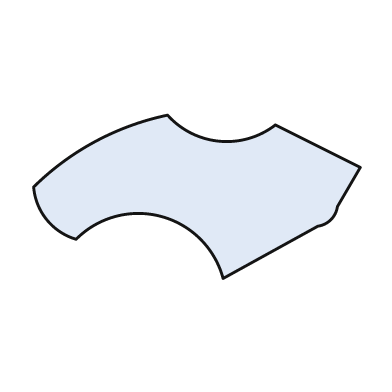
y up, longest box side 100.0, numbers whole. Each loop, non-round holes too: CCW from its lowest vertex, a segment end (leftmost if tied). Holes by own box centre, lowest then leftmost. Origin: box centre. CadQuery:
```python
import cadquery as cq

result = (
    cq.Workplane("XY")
    .moveTo(8.0, -25.0)
    .lineTo(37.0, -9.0)
    .threePointArc((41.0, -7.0), (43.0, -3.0))
    .lineTo(50.0, 9.0)
    .lineTo(24.0, 22.0)
    .threePointArc((7.0, 17.0), (-9.0, 25.0))
    .threePointArc((-31.0, 17.0), (-50.0, 3.0))
    .threePointArc((-46.0, -7.0), (-37.0, -13.0))
    .threePointArc((-11.0, -6.0), (8.0, -25.0))
    .close()
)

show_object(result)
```